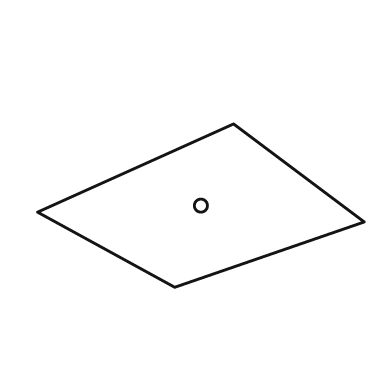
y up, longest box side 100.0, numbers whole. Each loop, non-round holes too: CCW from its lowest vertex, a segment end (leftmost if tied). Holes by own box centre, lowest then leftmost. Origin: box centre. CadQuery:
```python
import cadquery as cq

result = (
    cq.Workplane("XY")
    .moveTo(-8.0, -25.0)
    .lineTo(50.0, -5.0)
    .lineTo(10.0, 25.0)
    .lineTo(-50.0, -2.0)
    .close()
    .moveTo(0.0, 0.0)
    .circle(2.0)
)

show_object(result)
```